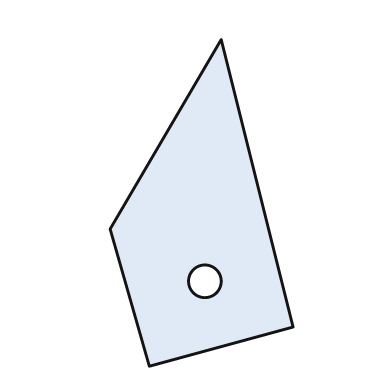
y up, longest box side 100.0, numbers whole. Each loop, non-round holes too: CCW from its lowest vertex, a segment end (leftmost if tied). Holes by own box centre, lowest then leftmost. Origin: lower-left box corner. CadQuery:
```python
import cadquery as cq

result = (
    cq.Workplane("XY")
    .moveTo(12.0, 0.0)
    .lineTo(56.0, 12.0)
    .lineTo(34.0, 100.0)
    .lineTo(0.0, 42.0)
    .close()
    .moveTo(29.0, 26.0)
    .circle(5.0)
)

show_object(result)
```